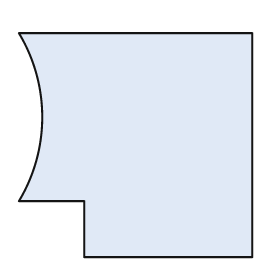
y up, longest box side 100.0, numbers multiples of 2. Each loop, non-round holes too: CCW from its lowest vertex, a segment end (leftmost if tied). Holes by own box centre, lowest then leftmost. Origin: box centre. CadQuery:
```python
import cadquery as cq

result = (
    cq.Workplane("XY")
    .moveTo(-22.0, -48.0)
    .lineTo(50.0, -48.0)
    .lineTo(50.0, 48.0)
    .lineTo(-50.0, 48.0)
    .threePointArc((-40.0, 12.0), (-50.0, -24.0))
    .lineTo(-22.0, -24.0)
    .close()
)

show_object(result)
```